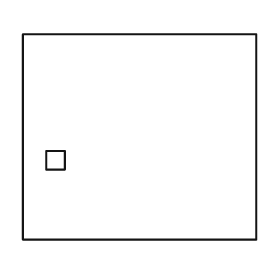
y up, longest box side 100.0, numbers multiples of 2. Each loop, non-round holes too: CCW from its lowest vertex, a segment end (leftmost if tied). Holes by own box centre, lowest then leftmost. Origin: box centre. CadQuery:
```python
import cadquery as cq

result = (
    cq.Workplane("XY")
    .moveTo(-50.0, -44.0)
    .lineTo(50.0, -44.0)
    .lineTo(50.0, 44.0)
    .lineTo(-50.0, 44.0)
    .close()
    .moveTo(-40.0, -14.0)
    .lineTo(-32.0, -14.0)
    .lineTo(-32.0, -6.0)
    .lineTo(-40.0, -6.0)
    .close()
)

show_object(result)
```